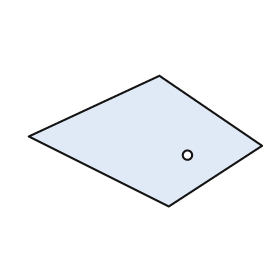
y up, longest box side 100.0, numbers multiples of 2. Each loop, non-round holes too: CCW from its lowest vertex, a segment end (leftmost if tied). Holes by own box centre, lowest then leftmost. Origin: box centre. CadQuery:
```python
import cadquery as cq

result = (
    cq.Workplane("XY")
    .moveTo(10.0, -28.0)
    .lineTo(50.0, -2.0)
    .lineTo(6.0, 28.0)
    .lineTo(-50.0, 2.0)
    .close()
    .moveTo(18.0, -6.0)
    .circle(2.0)
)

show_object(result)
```